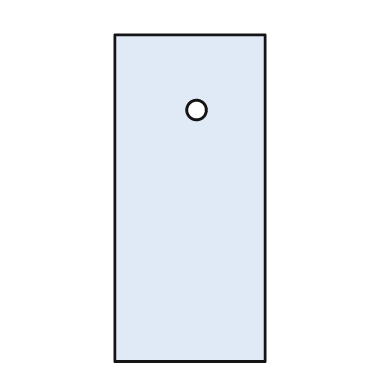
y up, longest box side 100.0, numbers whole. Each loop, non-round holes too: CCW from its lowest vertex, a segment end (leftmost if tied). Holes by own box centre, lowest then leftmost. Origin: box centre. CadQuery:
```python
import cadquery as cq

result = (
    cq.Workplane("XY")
    .moveTo(-23.0, -50.0)
    .lineTo(23.0, -50.0)
    .lineTo(23.0, 50.0)
    .lineTo(-23.0, 50.0)
    .close()
    .moveTo(2.0, 27.0)
    .circle(3.0)
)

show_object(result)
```